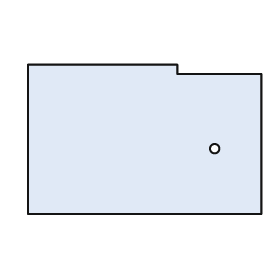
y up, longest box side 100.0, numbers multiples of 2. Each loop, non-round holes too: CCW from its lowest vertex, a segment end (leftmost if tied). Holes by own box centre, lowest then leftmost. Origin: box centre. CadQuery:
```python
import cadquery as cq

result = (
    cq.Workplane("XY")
    .moveTo(-50.0, -32.0)
    .lineTo(50.0, -32.0)
    .lineTo(50.0, 28.0)
    .lineTo(14.0, 28.0)
    .lineTo(14.0, 32.0)
    .lineTo(-50.0, 32.0)
    .close()
    .moveTo(30.0, -4.0)
    .circle(2.0)
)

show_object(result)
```